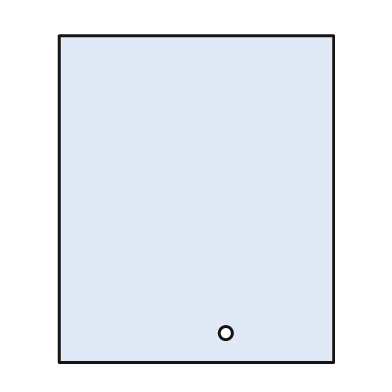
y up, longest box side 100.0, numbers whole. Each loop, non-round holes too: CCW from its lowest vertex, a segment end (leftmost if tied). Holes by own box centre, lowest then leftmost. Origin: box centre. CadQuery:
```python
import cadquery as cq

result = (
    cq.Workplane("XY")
    .moveTo(-42.0, -50.0)
    .lineTo(42.0, -50.0)
    .lineTo(42.0, 50.0)
    .lineTo(-42.0, 50.0)
    .close()
    .moveTo(9.0, -41.0)
    .circle(2.0)
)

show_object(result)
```